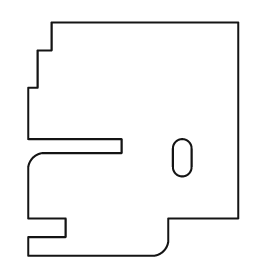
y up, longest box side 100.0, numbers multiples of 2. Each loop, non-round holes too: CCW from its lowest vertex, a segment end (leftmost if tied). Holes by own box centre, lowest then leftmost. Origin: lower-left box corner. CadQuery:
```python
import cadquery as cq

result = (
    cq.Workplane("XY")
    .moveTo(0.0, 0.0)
    .lineTo(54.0, 0.0)
    .threePointArc((58.0, 2.0), (60.0, 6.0))
    .lineTo(60.0, 16.0)
    .lineTo(90.0, 16.0)
    .lineTo(90.0, 100.0)
    .lineTo(10.0, 100.0)
    .lineTo(10.0, 88.0)
    .lineTo(4.0, 88.0)
    .lineTo(4.0, 72.0)
    .lineTo(0.0, 72.0)
    .lineTo(0.0, 50.0)
    .lineTo(40.0, 50.0)
    .lineTo(40.0, 44.0)
    .lineTo(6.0, 44.0)
    .threePointArc((2.0, 42.0), (0.0, 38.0))
    .lineTo(0.0, 16.0)
    .lineTo(16.0, 16.0)
    .lineTo(16.0, 8.0)
    .lineTo(0.0, 8.0)
    .close()
    .moveTo(62.0, 38.0)
    .threePointArc((66.0, 34.0), (70.0, 38.0))
    .lineTo(70.0, 46.0)
    .threePointArc((66.0, 50.0), (62.0, 46.0))
    .close()
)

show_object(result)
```